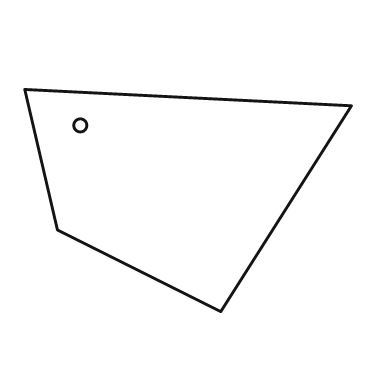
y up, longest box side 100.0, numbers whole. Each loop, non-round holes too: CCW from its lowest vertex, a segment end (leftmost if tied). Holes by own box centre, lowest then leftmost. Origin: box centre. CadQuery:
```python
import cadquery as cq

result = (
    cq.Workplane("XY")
    .moveTo(10.0, -34.0)
    .lineTo(50.0, 29.0)
    .lineTo(-50.0, 34.0)
    .lineTo(-40.0, -9.0)
    .close()
    .moveTo(-33.0, 23.0)
    .circle(2.0)
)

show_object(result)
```